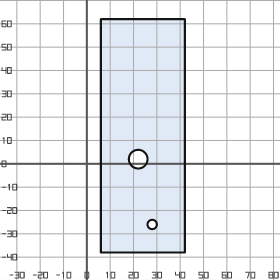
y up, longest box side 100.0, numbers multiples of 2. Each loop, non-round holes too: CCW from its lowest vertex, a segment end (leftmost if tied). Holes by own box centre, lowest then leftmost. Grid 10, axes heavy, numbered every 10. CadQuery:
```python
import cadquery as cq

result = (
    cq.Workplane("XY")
    .moveTo(6.0, -38.0)
    .lineTo(42.0, -38.0)
    .lineTo(42.0, 62.0)
    .lineTo(6.0, 62.0)
    .close()
    .moveTo(28.0, -26.0)
    .circle(2.0)
    .moveTo(22.0, 2.0)
    .circle(4.0)
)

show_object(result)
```